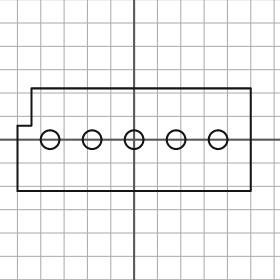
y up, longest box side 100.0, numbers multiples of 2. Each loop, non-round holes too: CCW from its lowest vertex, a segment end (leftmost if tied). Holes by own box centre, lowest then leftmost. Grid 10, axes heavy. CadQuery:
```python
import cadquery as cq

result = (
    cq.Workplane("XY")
    .moveTo(-50.0, -22.0)
    .lineTo(50.0, -22.0)
    .lineTo(50.0, 22.0)
    .lineTo(-44.0, 22.0)
    .lineTo(-44.0, 6.0)
    .lineTo(-50.0, 6.0)
    .close()
    .moveTo(-36.0, 0.0)
    .circle(4.0)
    .moveTo(-18.0, 0.0)
    .circle(4.0)
    .moveTo(0.0, 0.0)
    .circle(4.0)
    .moveTo(18.0, 0.0)
    .circle(4.0)
    .moveTo(36.0, 0.0)
    .circle(4.0)
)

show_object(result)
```